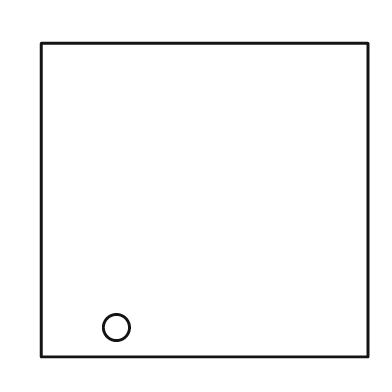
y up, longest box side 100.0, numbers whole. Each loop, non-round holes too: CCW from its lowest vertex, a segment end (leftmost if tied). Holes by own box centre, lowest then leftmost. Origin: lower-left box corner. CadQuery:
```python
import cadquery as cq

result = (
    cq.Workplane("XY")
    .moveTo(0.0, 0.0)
    .lineTo(100.0, 0.0)
    .lineTo(100.0, 96.0)
    .lineTo(0.0, 96.0)
    .close()
    .moveTo(23.0, 9.0)
    .circle(4.0)
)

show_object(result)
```